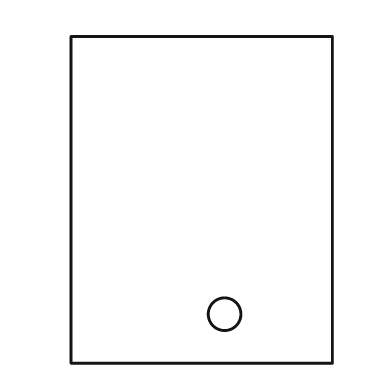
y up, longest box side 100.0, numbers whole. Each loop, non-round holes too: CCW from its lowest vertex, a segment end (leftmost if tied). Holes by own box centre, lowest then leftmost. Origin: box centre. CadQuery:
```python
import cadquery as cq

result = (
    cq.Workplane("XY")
    .moveTo(-40.0, -50.0)
    .lineTo(40.0, -50.0)
    .lineTo(40.0, 50.0)
    .lineTo(-40.0, 50.0)
    .close()
    .moveTo(7.0, -35.0)
    .circle(5.0)
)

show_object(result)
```